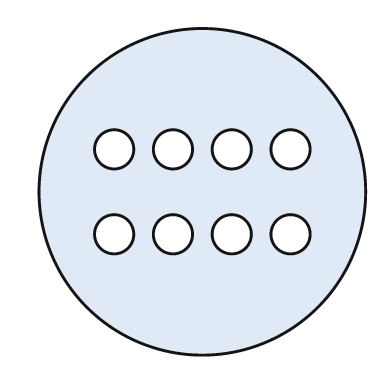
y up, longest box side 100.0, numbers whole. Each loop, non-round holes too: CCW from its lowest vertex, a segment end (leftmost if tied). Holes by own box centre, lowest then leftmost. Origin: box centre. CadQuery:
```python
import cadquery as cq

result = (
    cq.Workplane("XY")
    .moveTo(0.0, 0.0)
    .circle(50.0)
    .moveTo(-27.0, -13.0)
    .circle(6.0)
    .moveTo(-9.0, -13.0)
    .circle(6.0)
    .moveTo(9.0, -13.0)
    .circle(6.0)
    .moveTo(27.0, -13.0)
    .circle(6.0)
    .moveTo(-27.0, 13.0)
    .circle(6.0)
    .moveTo(-9.0, 13.0)
    .circle(6.0)
    .moveTo(9.0, 13.0)
    .circle(6.0)
    .moveTo(27.0, 13.0)
    .circle(6.0)
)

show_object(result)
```